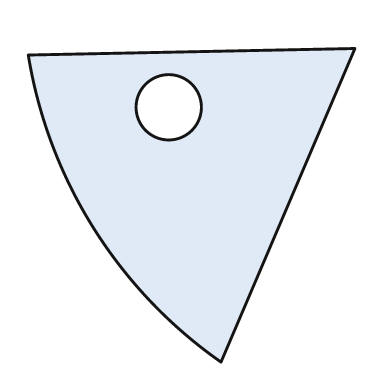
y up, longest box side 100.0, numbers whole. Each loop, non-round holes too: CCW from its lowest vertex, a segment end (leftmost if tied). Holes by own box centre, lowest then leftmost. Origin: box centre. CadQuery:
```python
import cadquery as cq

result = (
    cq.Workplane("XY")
    .moveTo(9.0, -48.0)
    .lineTo(50.0, 48.0)
    .lineTo(-50.0, 46.0)
    .threePointArc((-30.0, -7.0), (9.0, -48.0))
    .close()
    .moveTo(-7.0, 30.0)
    .circle(10.0)
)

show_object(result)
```